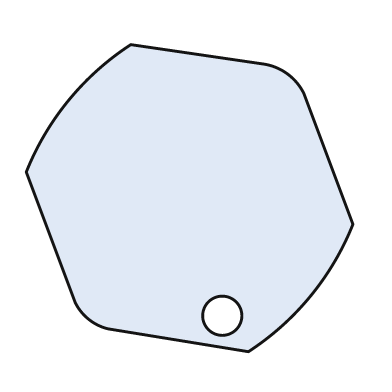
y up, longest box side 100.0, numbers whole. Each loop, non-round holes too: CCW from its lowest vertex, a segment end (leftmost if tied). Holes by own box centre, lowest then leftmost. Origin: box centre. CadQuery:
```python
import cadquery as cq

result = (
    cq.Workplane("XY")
    .moveTo(18.0, -47.0)
    .threePointArc((37.0, -30.0), (50.0, -8.0))
    .lineTo(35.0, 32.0)
    .threePointArc((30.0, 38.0), (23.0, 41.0))
    .lineTo(-18.0, 47.0)
    .threePointArc((-37.0, 30.0), (-50.0, 8.0))
    .lineTo(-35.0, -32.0)
    .threePointArc((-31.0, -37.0), (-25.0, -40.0))
    .close()
    .moveTo(10.0, -36.0)
    .circle(6.0)
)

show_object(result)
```